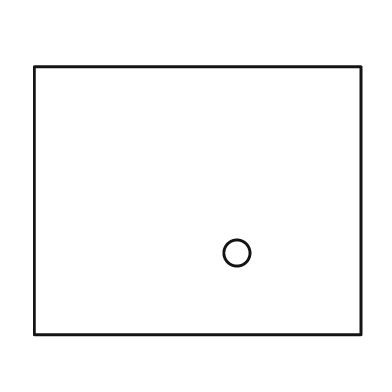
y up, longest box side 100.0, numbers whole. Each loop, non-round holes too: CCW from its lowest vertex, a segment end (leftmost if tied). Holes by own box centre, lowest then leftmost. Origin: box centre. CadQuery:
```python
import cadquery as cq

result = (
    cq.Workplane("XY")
    .moveTo(-50.0, -41.0)
    .lineTo(50.0, -41.0)
    .lineTo(50.0, 41.0)
    .lineTo(-50.0, 41.0)
    .close()
    .moveTo(12.0, -16.0)
    .circle(4.0)
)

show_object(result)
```